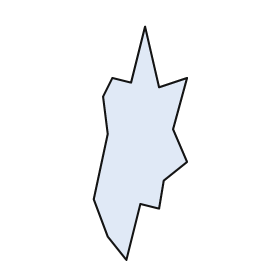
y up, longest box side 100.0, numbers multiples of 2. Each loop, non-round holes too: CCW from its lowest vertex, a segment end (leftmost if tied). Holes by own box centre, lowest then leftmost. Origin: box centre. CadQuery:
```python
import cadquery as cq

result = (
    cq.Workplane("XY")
    .moveTo(-6.0, -50.0)
    .lineTo(0.0, -26.0)
    .lineTo(8.0, -28.0)
    .lineTo(10.0, -16.0)
    .lineTo(20.0, -8.0)
    .lineTo(14.0, 6.0)
    .lineTo(20.0, 28.0)
    .lineTo(8.0, 24.0)
    .lineTo(2.0, 50.0)
    .lineTo(-4.0, 26.0)
    .lineTo(-12.0, 28.0)
    .lineTo(-16.0, 20.0)
    .lineTo(-14.0, 4.0)
    .lineTo(-20.0, -24.0)
    .lineTo(-14.0, -40.0)
    .close()
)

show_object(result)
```